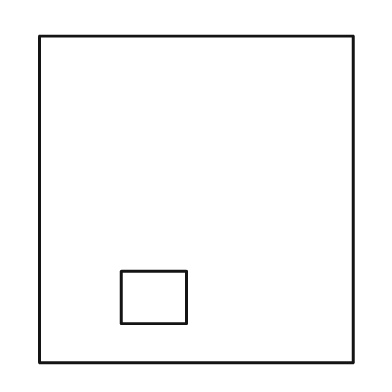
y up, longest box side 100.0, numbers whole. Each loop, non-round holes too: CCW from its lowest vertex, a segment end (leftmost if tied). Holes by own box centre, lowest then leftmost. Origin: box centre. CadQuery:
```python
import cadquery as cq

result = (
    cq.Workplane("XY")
    .moveTo(-48.0, -50.0)
    .lineTo(48.0, -50.0)
    .lineTo(48.0, 50.0)
    .lineTo(-48.0, 50.0)
    .close()
    .moveTo(-23.0, -38.0)
    .lineTo(-3.0, -38.0)
    .lineTo(-3.0, -22.0)
    .lineTo(-23.0, -22.0)
    .close()
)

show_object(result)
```